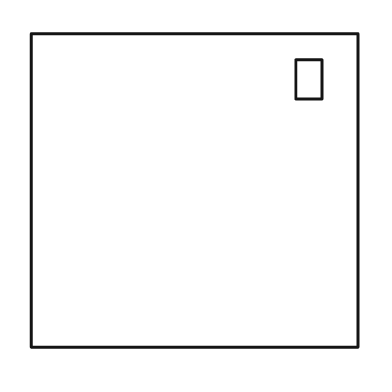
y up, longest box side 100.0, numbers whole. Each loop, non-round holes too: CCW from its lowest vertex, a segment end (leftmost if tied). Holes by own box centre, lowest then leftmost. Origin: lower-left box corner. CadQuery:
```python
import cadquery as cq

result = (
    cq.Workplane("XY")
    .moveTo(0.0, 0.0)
    .lineTo(100.0, 0.0)
    .lineTo(100.0, 96.0)
    .lineTo(0.0, 96.0)
    .close()
    .moveTo(81.0, 76.0)
    .lineTo(89.0, 76.0)
    .lineTo(89.0, 88.0)
    .lineTo(81.0, 88.0)
    .close()
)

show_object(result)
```